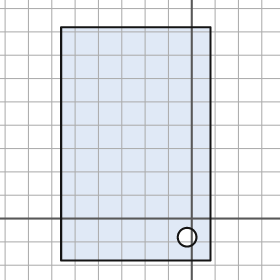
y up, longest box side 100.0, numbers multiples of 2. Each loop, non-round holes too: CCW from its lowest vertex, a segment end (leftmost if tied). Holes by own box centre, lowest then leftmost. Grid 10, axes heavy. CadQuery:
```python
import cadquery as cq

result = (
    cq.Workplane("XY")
    .moveTo(-56.0, -18.0)
    .lineTo(8.0, -18.0)
    .lineTo(8.0, 82.0)
    .lineTo(-56.0, 82.0)
    .close()
    .moveTo(-2.0, -8.0)
    .circle(4.0)
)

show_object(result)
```